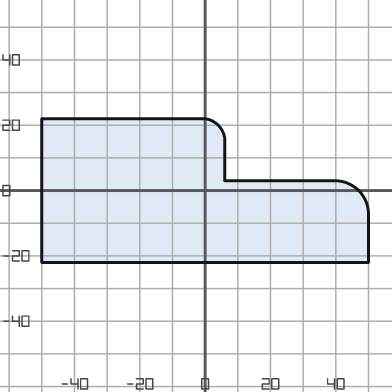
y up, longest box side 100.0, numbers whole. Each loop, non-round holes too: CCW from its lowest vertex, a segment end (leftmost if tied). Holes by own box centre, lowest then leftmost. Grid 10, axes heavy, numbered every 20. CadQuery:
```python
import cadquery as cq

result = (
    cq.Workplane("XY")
    .moveTo(-50.0, -22.0)
    .lineTo(50.0, -22.0)
    .lineTo(50.0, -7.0)
    .threePointArc((47.0, 0.0), (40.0, 3.0))
    .lineTo(6.0, 3.0)
    .lineTo(6.0, 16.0)
    .threePointArc((4.0, 20.0), (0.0, 22.0))
    .lineTo(-50.0, 22.0)
    .close()
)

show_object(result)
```